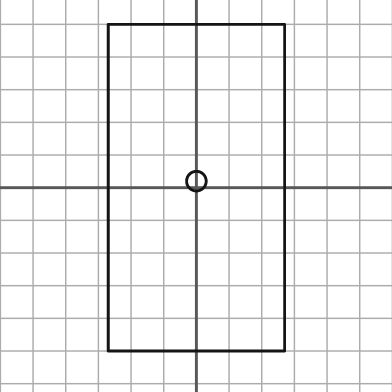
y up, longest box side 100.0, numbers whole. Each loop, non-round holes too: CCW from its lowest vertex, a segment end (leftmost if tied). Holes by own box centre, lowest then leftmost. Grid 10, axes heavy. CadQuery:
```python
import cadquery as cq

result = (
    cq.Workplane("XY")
    .moveTo(-27.0, -50.0)
    .lineTo(27.0, -50.0)
    .lineTo(27.0, 50.0)
    .lineTo(-27.0, 50.0)
    .close()
    .moveTo(0.0, 2.0)
    .circle(3.0)
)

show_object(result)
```